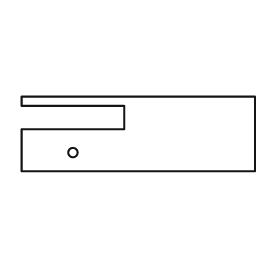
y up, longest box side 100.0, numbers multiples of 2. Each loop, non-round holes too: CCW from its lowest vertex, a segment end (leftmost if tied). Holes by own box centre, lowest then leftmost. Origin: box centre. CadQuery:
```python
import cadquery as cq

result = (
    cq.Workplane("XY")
    .moveTo(-50.0, -16.0)
    .lineTo(50.0, -16.0)
    .lineTo(50.0, 16.0)
    .lineTo(-50.0, 16.0)
    .lineTo(-50.0, 12.0)
    .lineTo(-6.0, 12.0)
    .lineTo(-6.0, 2.0)
    .lineTo(-50.0, 2.0)
    .close()
    .moveTo(-28.0, -8.0)
    .circle(2.0)
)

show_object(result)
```